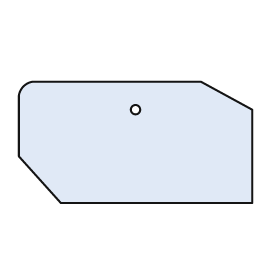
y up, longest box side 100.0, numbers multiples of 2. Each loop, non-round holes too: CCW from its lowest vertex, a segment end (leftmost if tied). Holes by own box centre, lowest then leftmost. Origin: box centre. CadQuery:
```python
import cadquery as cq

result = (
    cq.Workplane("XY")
    .moveTo(-32.0, -26.0)
    .lineTo(50.0, -26.0)
    .lineTo(50.0, 14.0)
    .lineTo(28.0, 26.0)
    .lineTo(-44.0, 26.0)
    .threePointArc((-48.0, 24.0), (-50.0, 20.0))
    .lineTo(-50.0, -6.0)
    .close()
    .moveTo(0.0, 14.0)
    .circle(2.0)
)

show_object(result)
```